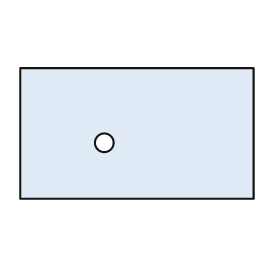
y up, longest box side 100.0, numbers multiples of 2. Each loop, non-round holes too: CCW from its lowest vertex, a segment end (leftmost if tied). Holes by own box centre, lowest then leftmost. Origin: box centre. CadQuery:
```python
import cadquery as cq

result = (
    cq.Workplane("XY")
    .moveTo(-50.0, -28.0)
    .lineTo(50.0, -28.0)
    .lineTo(50.0, 28.0)
    .lineTo(-50.0, 28.0)
    .close()
    .moveTo(-14.0, -4.0)
    .circle(4.0)
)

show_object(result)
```